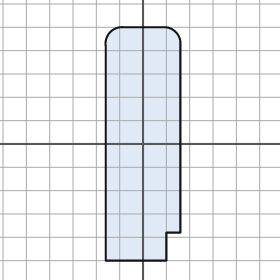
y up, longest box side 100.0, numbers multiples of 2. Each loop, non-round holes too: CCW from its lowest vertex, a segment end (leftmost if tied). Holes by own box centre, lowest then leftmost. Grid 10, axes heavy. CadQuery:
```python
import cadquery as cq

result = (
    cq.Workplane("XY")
    .moveTo(-16.0, -50.0)
    .lineTo(10.0, -50.0)
    .lineTo(10.0, -38.0)
    .lineTo(16.0, -38.0)
    .lineTo(16.0, 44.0)
    .threePointArc((14.0, 48.0), (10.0, 50.0))
    .lineTo(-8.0, 50.0)
    .threePointArc((-14.0, 48.0), (-16.0, 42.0))
    .close()
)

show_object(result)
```